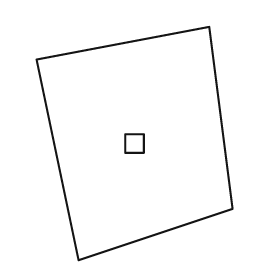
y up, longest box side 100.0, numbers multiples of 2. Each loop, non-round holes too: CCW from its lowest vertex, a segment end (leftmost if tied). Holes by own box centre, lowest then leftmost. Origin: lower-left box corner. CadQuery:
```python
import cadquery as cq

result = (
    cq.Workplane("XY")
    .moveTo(18.0, 0.0)
    .lineTo(84.0, 22.0)
    .lineTo(74.0, 100.0)
    .lineTo(0.0, 86.0)
    .close()
    .moveTo(38.0, 46.0)
    .lineTo(46.0, 46.0)
    .lineTo(46.0, 54.0)
    .lineTo(38.0, 54.0)
    .close()
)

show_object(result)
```